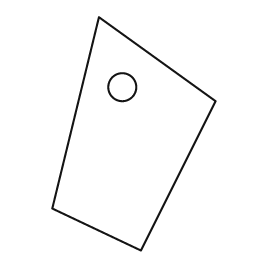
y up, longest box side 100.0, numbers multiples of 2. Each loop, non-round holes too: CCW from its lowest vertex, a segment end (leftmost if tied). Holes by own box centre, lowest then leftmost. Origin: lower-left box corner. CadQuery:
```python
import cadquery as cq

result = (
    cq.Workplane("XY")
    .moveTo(38.0, 0.0)
    .lineTo(70.0, 64.0)
    .lineTo(20.0, 100.0)
    .lineTo(0.0, 18.0)
    .close()
    .moveTo(30.0, 70.0)
    .circle(6.0)
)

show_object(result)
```